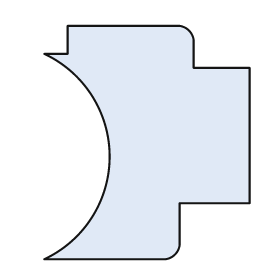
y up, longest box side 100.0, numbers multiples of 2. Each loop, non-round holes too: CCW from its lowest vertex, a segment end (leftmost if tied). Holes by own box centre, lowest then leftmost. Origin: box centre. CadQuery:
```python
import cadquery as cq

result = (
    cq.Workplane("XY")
    .moveTo(-44.0, -50.0)
    .lineTo(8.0, -50.0)
    .threePointArc((12.0, -48.0), (14.0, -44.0))
    .lineTo(14.0, -26.0)
    .lineTo(44.0, -26.0)
    .lineTo(44.0, 32.0)
    .lineTo(20.0, 32.0)
    .lineTo(20.0, 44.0)
    .threePointArc((18.0, 48.0), (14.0, 50.0))
    .lineTo(-34.0, 50.0)
    .lineTo(-34.0, 38.0)
    .lineTo(-44.0, 38.0)
    .threePointArc((-16.0, -6.0), (-44.0, -50.0))
    .close()
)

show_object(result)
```